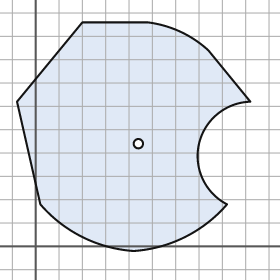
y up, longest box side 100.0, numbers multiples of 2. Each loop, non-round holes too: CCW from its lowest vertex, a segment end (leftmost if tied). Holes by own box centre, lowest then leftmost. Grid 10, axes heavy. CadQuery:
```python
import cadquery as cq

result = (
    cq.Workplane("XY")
    .moveTo(42.0, -2.0)
    .threePointArc((64.0, 4.0), (82.0, 18.0))
    .threePointArc((70.0, 44.0), (92.0, 62.0))
    .lineTo(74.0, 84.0)
    .threePointArc((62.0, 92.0), (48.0, 96.0))
    .lineTo(20.0, 96.0)
    .lineTo(-8.0, 62.0)
    .lineTo(2.0, 18.0)
    .threePointArc((20.0, 4.0), (42.0, -2.0))
    .close()
    .moveTo(44.0, 44.0)
    .circle(2.0)
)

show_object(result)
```